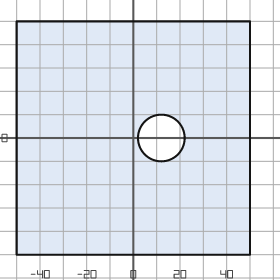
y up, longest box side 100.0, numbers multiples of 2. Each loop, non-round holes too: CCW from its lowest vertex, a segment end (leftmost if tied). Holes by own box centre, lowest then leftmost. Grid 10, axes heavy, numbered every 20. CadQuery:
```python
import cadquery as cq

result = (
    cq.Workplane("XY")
    .moveTo(-50.0, -50.0)
    .lineTo(50.0, -50.0)
    .lineTo(50.0, 50.0)
    .lineTo(-50.0, 50.0)
    .close()
    .moveTo(12.0, 0.0)
    .circle(10.0)
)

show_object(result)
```